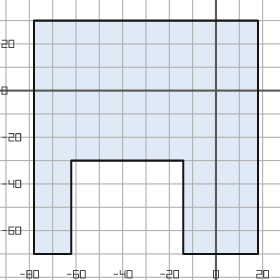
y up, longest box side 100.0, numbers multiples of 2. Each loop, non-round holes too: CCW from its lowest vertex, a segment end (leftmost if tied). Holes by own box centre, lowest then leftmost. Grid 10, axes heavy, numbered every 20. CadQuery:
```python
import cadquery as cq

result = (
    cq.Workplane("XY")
    .moveTo(-78.0, -70.0)
    .lineTo(-62.0, -70.0)
    .lineTo(-62.0, -30.0)
    .lineTo(-14.0, -30.0)
    .lineTo(-14.0, -70.0)
    .lineTo(18.0, -70.0)
    .lineTo(18.0, 30.0)
    .lineTo(-78.0, 30.0)
    .close()
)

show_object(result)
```